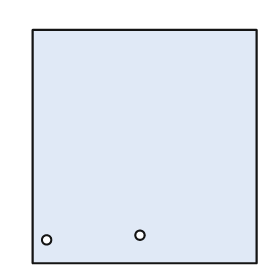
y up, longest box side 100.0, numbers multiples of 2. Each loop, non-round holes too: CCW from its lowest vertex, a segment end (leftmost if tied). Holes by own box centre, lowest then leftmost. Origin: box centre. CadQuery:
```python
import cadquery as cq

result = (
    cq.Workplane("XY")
    .moveTo(-48.0, -50.0)
    .lineTo(48.0, -50.0)
    .lineTo(48.0, 50.0)
    .lineTo(-48.0, 50.0)
    .close()
    .moveTo(-42.0, -40.0)
    .circle(2.0)
    .moveTo(-2.0, -38.0)
    .circle(2.0)
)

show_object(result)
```